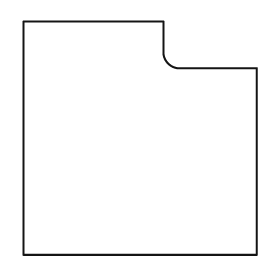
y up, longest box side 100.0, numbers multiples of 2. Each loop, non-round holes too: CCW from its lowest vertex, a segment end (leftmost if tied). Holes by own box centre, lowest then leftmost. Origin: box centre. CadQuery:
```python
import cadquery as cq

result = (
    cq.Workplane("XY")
    .moveTo(-50.0, -50.0)
    .lineTo(50.0, -50.0)
    .lineTo(50.0, 30.0)
    .lineTo(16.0, 30.0)
    .threePointArc((12.0, 32.0), (10.0, 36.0))
    .lineTo(10.0, 50.0)
    .lineTo(-50.0, 50.0)
    .close()
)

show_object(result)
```